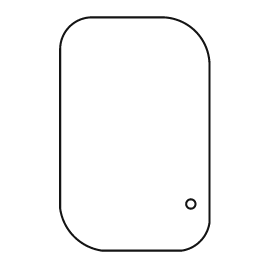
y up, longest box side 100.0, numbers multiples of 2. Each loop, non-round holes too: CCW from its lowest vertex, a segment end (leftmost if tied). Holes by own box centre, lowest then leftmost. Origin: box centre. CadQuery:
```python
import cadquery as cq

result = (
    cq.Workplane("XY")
    .moveTo(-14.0, -50.0)
    .lineTo(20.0, -50.0)
    .threePointArc((28.0, -46.0), (32.0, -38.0))
    .lineTo(32.0, 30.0)
    .threePointArc((26.0, 44.0), (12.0, 50.0))
    .lineTo(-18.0, 50.0)
    .threePointArc((-28.0, 46.0), (-32.0, 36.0))
    .lineTo(-32.0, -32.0)
    .threePointArc((-26.0, -44.0), (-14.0, -50.0))
    .close()
    .moveTo(24.0, -30.0)
    .circle(2.0)
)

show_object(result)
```